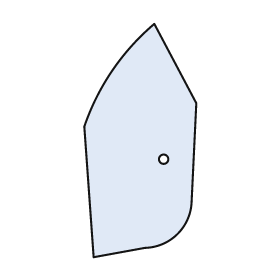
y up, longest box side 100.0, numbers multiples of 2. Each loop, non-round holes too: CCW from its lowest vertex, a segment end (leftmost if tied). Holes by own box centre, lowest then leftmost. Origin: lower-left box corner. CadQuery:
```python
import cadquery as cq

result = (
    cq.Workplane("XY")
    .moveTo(4.0, 0.0)
    .lineTo(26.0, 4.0)
    .threePointArc((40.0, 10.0), (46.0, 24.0))
    .lineTo(48.0, 66.0)
    .lineTo(30.0, 100.0)
    .threePointArc((12.0, 80.0), (0.0, 56.0))
    .close()
    .moveTo(34.0, 42.0)
    .circle(2.0)
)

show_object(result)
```